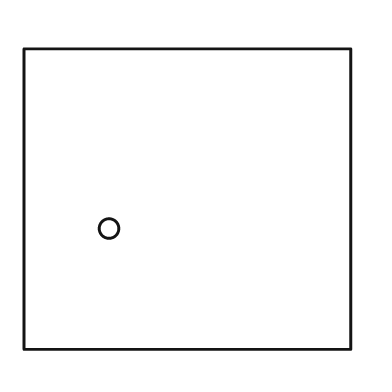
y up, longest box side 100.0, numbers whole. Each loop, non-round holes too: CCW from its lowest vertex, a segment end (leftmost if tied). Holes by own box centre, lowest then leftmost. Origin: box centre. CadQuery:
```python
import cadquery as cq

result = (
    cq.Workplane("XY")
    .moveTo(-50.0, -46.0)
    .lineTo(50.0, -46.0)
    .lineTo(50.0, 46.0)
    .lineTo(-50.0, 46.0)
    .close()
    .moveTo(-24.0, -9.0)
    .circle(3.0)
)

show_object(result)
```